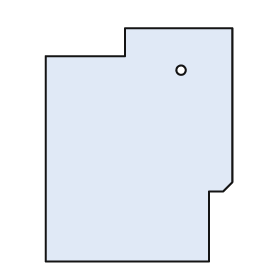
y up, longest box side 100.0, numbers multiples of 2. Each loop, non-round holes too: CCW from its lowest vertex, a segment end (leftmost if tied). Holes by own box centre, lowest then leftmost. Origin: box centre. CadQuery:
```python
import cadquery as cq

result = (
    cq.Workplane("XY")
    .moveTo(-40.0, -50.0)
    .lineTo(30.0, -50.0)
    .lineTo(30.0, -20.0)
    .lineTo(36.0, -20.0)
    .lineTo(40.0, -16.0)
    .lineTo(40.0, 50.0)
    .lineTo(-6.0, 50.0)
    .lineTo(-6.0, 38.0)
    .lineTo(-40.0, 38.0)
    .close()
    .moveTo(18.0, 32.0)
    .circle(2.0)
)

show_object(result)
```